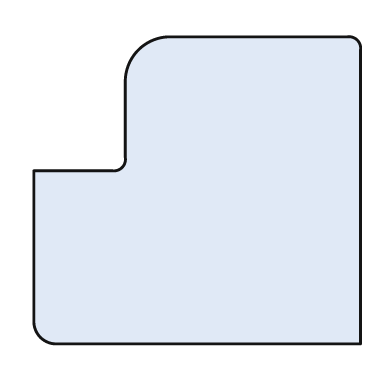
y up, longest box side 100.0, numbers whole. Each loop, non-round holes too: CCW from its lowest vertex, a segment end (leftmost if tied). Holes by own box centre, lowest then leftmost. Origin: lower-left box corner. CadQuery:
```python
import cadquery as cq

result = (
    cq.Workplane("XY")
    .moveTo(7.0, 0.0)
    .lineTo(100.0, 0.0)
    .lineTo(100.0, 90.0)
    .threePointArc((99.0, 93.0), (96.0, 94.0))
    .lineTo(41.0, 94.0)
    .threePointArc((32.0, 90.0), (28.0, 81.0))
    .lineTo(28.0, 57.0)
    .threePointArc((27.0, 54.0), (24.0, 53.0))
    .lineTo(0.0, 53.0)
    .lineTo(0.0, 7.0)
    .threePointArc((2.0, 2.0), (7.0, 0.0))
    .close()
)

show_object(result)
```